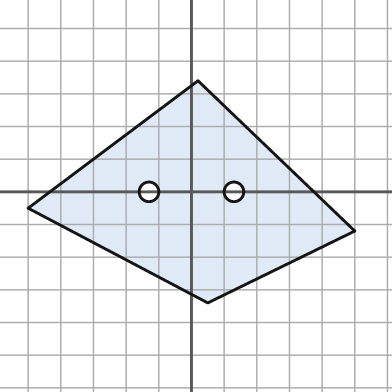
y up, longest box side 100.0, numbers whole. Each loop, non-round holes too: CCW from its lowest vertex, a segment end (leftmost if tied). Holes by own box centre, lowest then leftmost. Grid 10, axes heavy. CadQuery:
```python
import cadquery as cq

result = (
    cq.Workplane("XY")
    .moveTo(5.0, -34.0)
    .lineTo(50.0, -12.0)
    .lineTo(2.0, 34.0)
    .lineTo(-50.0, -5.0)
    .close()
    .moveTo(-13.0, 0.0)
    .circle(3.0)
    .moveTo(13.0, 0.0)
    .circle(3.0)
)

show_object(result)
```